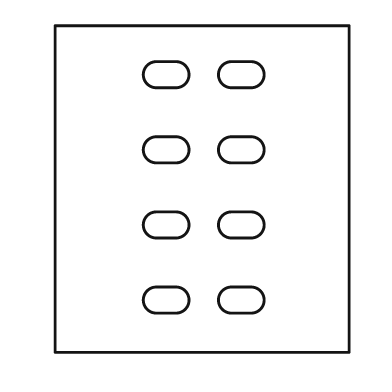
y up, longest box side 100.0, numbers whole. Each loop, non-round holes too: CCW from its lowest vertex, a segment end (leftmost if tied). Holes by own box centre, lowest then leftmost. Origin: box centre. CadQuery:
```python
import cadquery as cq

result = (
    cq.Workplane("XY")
    .moveTo(-45.0, -50.0)
    .lineTo(45.0, -50.0)
    .lineTo(45.0, 50.0)
    .lineTo(-45.0, 50.0)
    .close()
    .moveTo(-14.0, -38.0)
    .lineTo(-8.0, -38.0)
    .threePointArc((-4.0, -34.0), (-8.0, -30.0))
    .lineTo(-14.0, -30.0)
    .threePointArc((-18.0, -34.0), (-14.0, -38.0))
    .close()
    .moveTo(9.0, -38.0)
    .lineTo(15.0, -38.0)
    .threePointArc((19.0, -34.0), (15.0, -30.0))
    .lineTo(9.0, -30.0)
    .threePointArc((5.0, -34.0), (9.0, -38.0))
    .close()
    .moveTo(-14.0, -15.0)
    .lineTo(-8.0, -15.0)
    .threePointArc((-4.0, -11.0), (-8.0, -7.0))
    .lineTo(-14.0, -7.0)
    .threePointArc((-18.0, -11.0), (-14.0, -15.0))
    .close()
    .moveTo(9.0, -15.0)
    .lineTo(15.0, -15.0)
    .threePointArc((19.0, -11.0), (15.0, -7.0))
    .lineTo(9.0, -7.0)
    .threePointArc((5.0, -11.0), (9.0, -15.0))
    .close()
    .moveTo(-14.0, 8.0)
    .lineTo(-8.0, 8.0)
    .threePointArc((-4.0, 12.0), (-8.0, 16.0))
    .lineTo(-14.0, 16.0)
    .threePointArc((-18.0, 12.0), (-14.0, 8.0))
    .close()
    .moveTo(9.0, 8.0)
    .lineTo(15.0, 8.0)
    .threePointArc((19.0, 12.0), (15.0, 16.0))
    .lineTo(9.0, 16.0)
    .threePointArc((5.0, 12.0), (9.0, 8.0))
    .close()
    .moveTo(-14.0, 31.0)
    .lineTo(-8.0, 31.0)
    .threePointArc((-4.0, 35.0), (-8.0, 39.0))
    .lineTo(-14.0, 39.0)
    .threePointArc((-18.0, 35.0), (-14.0, 31.0))
    .close()
    .moveTo(9.0, 31.0)
    .lineTo(15.0, 31.0)
    .threePointArc((19.0, 35.0), (15.0, 39.0))
    .lineTo(9.0, 39.0)
    .threePointArc((5.0, 35.0), (9.0, 31.0))
    .close()
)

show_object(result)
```